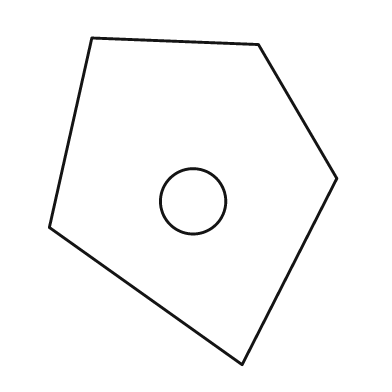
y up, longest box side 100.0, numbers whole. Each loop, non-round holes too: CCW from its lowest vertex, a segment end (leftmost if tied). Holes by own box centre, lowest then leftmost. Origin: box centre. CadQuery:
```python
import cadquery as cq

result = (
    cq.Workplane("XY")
    .moveTo(15.0, -50.0)
    .lineTo(44.0, 7.0)
    .lineTo(20.0, 48.0)
    .lineTo(-31.0, 50.0)
    .lineTo(-44.0, -8.0)
    .close()
    .moveTo(0.0, 0.0)
    .circle(10.0)
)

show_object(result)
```